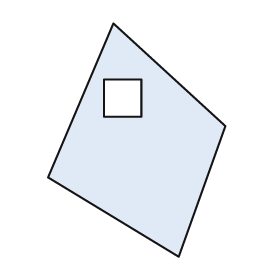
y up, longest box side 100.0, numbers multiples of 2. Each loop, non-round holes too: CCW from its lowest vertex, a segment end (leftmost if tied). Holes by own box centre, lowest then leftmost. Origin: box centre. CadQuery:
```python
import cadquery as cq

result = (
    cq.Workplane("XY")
    .moveTo(18.0, -50.0)
    .lineTo(38.0, 6.0)
    .lineTo(-10.0, 50.0)
    .lineTo(-38.0, -16.0)
    .close()
    .moveTo(-14.0, 10.0)
    .lineTo(2.0, 10.0)
    .lineTo(2.0, 26.0)
    .lineTo(-14.0, 26.0)
    .close()
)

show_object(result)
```